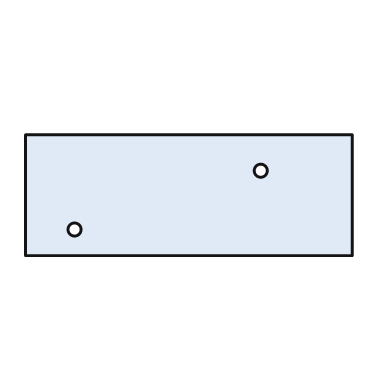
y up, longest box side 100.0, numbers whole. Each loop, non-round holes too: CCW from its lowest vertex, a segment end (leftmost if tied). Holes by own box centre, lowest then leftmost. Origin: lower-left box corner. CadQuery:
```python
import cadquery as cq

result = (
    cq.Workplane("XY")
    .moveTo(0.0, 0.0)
    .lineTo(100.0, 0.0)
    .lineTo(100.0, 37.0)
    .lineTo(0.0, 37.0)
    .close()
    .moveTo(15.0, 8.0)
    .circle(2.0)
    .moveTo(72.0, 26.0)
    .circle(2.0)
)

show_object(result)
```